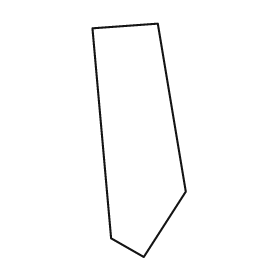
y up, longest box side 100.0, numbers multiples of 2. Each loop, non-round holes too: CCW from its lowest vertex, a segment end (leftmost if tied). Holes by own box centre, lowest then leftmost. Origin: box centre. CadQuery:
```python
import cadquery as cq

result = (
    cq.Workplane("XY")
    .moveTo(2.0, -50.0)
    .lineTo(20.0, -22.0)
    .lineTo(8.0, 50.0)
    .lineTo(-20.0, 48.0)
    .lineTo(-12.0, -42.0)
    .close()
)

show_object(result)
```